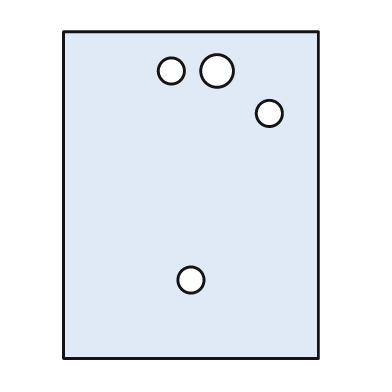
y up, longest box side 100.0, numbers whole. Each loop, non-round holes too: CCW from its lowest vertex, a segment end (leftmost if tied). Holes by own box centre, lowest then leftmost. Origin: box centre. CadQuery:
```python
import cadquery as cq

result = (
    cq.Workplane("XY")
    .moveTo(-39.0, -50.0)
    .lineTo(39.0, -50.0)
    .lineTo(39.0, 50.0)
    .lineTo(-39.0, 50.0)
    .close()
    .moveTo(0.0, -26.0)
    .circle(4.0)
    .moveTo(24.0, 25.0)
    .circle(4.0)
    .moveTo(-6.0, 38.0)
    .circle(4.0)
    .moveTo(8.0, 38.0)
    .circle(5.0)
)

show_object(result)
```